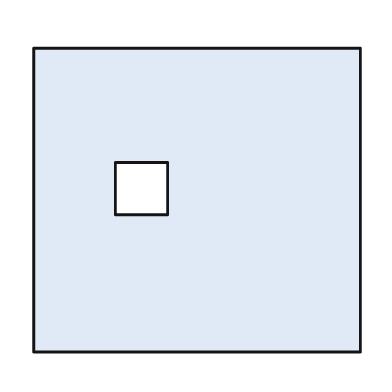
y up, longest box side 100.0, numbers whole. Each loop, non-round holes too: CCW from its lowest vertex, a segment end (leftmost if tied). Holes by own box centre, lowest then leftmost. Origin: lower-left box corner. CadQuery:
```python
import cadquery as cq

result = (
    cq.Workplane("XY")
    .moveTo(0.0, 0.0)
    .lineTo(100.0, 0.0)
    .lineTo(100.0, 93.0)
    .lineTo(0.0, 93.0)
    .close()
    .moveTo(25.0, 42.0)
    .lineTo(41.0, 42.0)
    .lineTo(41.0, 58.0)
    .lineTo(25.0, 58.0)
    .close()
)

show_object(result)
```